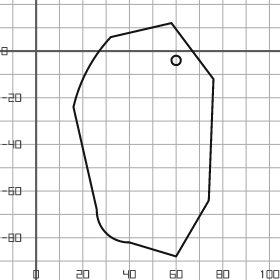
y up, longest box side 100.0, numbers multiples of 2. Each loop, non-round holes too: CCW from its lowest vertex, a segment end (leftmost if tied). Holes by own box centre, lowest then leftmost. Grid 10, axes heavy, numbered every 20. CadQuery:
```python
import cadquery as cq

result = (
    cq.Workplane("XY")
    .moveTo(60.0, -88.0)
    .lineTo(74.0, -64.0)
    .lineTo(76.0, -12.0)
    .lineTo(58.0, 12.0)
    .lineTo(32.0, 6.0)
    .threePointArc((22.0, -8.0), (16.0, -24.0))
    .lineTo(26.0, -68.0)
    .threePointArc((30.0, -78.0), (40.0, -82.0))
    .close()
    .moveTo(60.0, -4.0)
    .circle(2.0)
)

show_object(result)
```